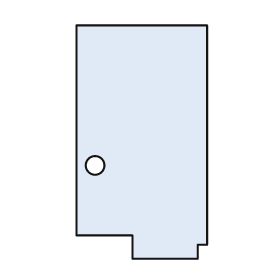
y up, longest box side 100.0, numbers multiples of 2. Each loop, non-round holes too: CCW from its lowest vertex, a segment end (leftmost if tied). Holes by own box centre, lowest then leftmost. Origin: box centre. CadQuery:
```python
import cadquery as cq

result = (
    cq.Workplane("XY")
    .moveTo(-4.0, -50.0)
    .lineTo(24.0, -50.0)
    .lineTo(24.0, -44.0)
    .lineTo(28.0, -44.0)
    .lineTo(28.0, 50.0)
    .lineTo(-28.0, 50.0)
    .lineTo(-28.0, -40.0)
    .lineTo(-4.0, -40.0)
    .close()
    .moveTo(-20.0, -10.0)
    .circle(4.0)
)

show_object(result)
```